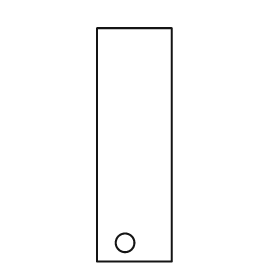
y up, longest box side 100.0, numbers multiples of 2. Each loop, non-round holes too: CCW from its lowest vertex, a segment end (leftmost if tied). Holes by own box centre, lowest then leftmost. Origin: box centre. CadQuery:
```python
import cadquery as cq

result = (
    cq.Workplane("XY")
    .moveTo(-16.0, -50.0)
    .lineTo(16.0, -50.0)
    .lineTo(16.0, 50.0)
    .lineTo(-16.0, 50.0)
    .close()
    .moveTo(-4.0, -42.0)
    .circle(4.0)
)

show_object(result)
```